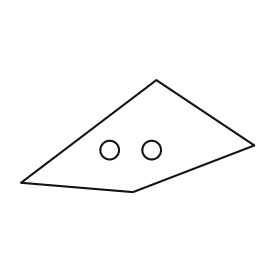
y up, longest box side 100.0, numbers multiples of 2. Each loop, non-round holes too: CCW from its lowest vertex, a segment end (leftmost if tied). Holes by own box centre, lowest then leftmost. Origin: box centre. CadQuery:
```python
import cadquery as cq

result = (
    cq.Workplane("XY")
    .moveTo(-2.0, -24.0)
    .lineTo(50.0, -4.0)
    .lineTo(8.0, 24.0)
    .lineTo(-50.0, -20.0)
    .close()
    .moveTo(-12.0, -6.0)
    .circle(4.0)
    .moveTo(6.0, -6.0)
    .circle(4.0)
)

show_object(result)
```